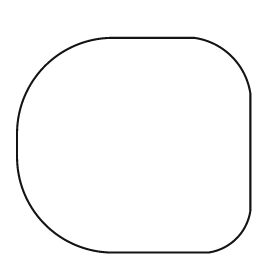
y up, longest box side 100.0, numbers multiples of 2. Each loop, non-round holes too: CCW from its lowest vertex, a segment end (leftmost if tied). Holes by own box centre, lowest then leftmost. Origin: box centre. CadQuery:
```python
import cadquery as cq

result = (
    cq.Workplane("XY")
    .moveTo(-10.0, -46.0)
    .lineTo(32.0, -46.0)
    .threePointArc((44.0, -40.0), (50.0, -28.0))
    .lineTo(50.0, 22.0)
    .threePointArc((42.0, 38.0), (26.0, 46.0))
    .lineTo(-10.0, 46.0)
    .threePointArc((-38.0, 34.0), (-50.0, 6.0))
    .lineTo(-50.0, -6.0)
    .threePointArc((-38.0, -34.0), (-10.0, -46.0))
    .close()
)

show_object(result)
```